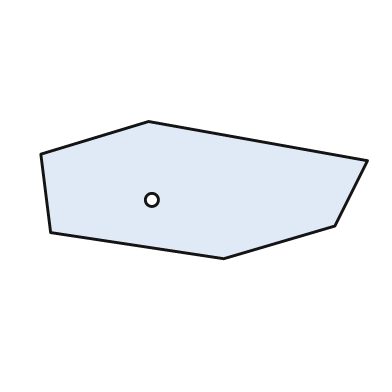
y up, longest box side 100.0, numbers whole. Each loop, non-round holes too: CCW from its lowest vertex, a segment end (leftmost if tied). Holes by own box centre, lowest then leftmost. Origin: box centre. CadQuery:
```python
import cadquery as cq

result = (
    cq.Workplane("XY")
    .moveTo(6.0, -21.0)
    .lineTo(40.0, -11.0)
    .lineTo(50.0, 9.0)
    .lineTo(-17.0, 21.0)
    .lineTo(-50.0, 11.0)
    .lineTo(-47.0, -13.0)
    .close()
    .moveTo(-16.0, -3.0)
    .circle(2.0)
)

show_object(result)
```